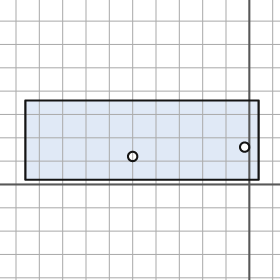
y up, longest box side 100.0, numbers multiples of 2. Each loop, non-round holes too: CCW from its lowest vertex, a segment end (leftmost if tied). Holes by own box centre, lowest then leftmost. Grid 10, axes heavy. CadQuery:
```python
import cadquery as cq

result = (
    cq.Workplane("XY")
    .moveTo(-96.0, 2.0)
    .lineTo(4.0, 2.0)
    .lineTo(4.0, 36.0)
    .lineTo(-96.0, 36.0)
    .close()
    .moveTo(-50.0, 12.0)
    .circle(2.0)
    .moveTo(-2.0, 16.0)
    .circle(2.0)
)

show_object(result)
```